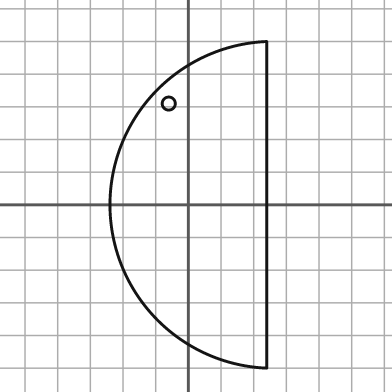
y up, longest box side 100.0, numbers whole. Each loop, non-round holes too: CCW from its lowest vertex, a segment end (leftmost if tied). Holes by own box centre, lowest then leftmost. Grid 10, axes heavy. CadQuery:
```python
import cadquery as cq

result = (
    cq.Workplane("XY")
    .moveTo(24.0, -50.0)
    .lineTo(24.0, 50.0)
    .threePointArc((-24.0, 0.0), (24.0, -50.0))
    .close()
    .moveTo(-6.0, 31.0)
    .circle(2.0)
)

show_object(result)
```